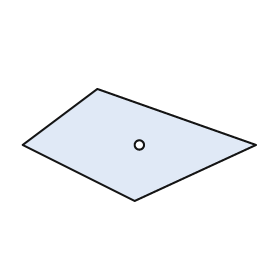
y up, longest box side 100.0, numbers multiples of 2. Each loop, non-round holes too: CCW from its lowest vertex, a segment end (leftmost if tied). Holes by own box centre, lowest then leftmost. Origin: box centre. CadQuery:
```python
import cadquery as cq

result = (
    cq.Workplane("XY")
    .moveTo(-2.0, -24.0)
    .lineTo(50.0, 0.0)
    .lineTo(-18.0, 24.0)
    .lineTo(-50.0, 0.0)
    .close()
    .moveTo(0.0, 0.0)
    .circle(2.0)
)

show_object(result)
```